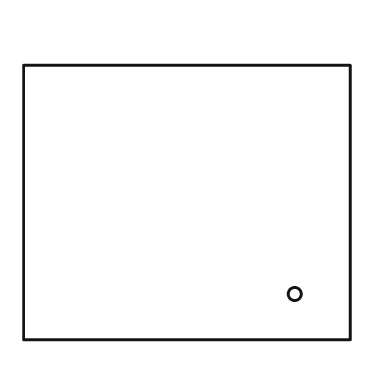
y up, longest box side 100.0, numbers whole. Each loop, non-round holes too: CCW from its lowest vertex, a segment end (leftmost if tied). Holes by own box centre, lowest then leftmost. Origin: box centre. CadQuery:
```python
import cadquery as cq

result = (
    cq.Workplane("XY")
    .moveTo(-50.0, -42.0)
    .lineTo(50.0, -42.0)
    .lineTo(50.0, 42.0)
    .lineTo(-50.0, 42.0)
    .close()
    .moveTo(33.0, -28.0)
    .circle(2.0)
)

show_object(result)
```